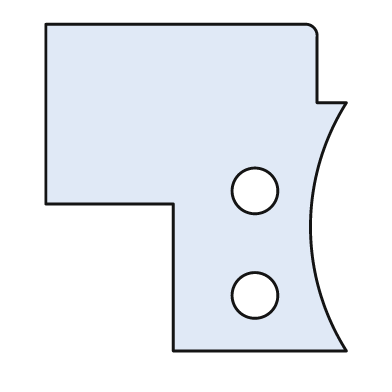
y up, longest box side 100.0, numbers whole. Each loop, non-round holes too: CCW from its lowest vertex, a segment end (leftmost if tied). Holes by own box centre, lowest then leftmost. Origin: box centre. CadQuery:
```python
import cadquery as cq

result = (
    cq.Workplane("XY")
    .moveTo(-7.0, -50.0)
    .lineTo(46.0, -50.0)
    .threePointArc((35.0, -12.0), (46.0, 26.0))
    .lineTo(37.0, 26.0)
    .lineTo(37.0, 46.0)
    .threePointArc((36.0, 49.0), (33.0, 50.0))
    .lineTo(-46.0, 50.0)
    .lineTo(-46.0, -5.0)
    .lineTo(-7.0, -5.0)
    .close()
    .moveTo(18.0, -33.0)
    .circle(7.0)
    .moveTo(18.0, -1.0)
    .circle(7.0)
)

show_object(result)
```